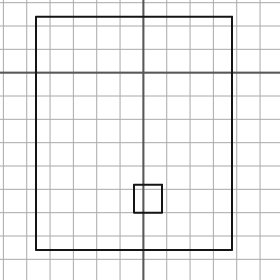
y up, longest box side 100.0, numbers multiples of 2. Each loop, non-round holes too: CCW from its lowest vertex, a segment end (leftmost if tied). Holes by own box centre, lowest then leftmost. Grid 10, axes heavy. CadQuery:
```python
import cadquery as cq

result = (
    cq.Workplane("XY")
    .moveTo(-46.0, -76.0)
    .lineTo(38.0, -76.0)
    .lineTo(38.0, 24.0)
    .lineTo(-46.0, 24.0)
    .close()
    .moveTo(-4.0, -60.0)
    .lineTo(8.0, -60.0)
    .lineTo(8.0, -48.0)
    .lineTo(-4.0, -48.0)
    .close()
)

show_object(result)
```